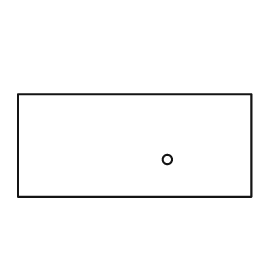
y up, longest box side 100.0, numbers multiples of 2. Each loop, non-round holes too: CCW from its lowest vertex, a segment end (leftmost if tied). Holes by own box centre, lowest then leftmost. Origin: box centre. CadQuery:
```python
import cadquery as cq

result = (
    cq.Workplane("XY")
    .moveTo(-50.0, -22.0)
    .lineTo(50.0, -22.0)
    .lineTo(50.0, 22.0)
    .lineTo(-50.0, 22.0)
    .close()
    .moveTo(14.0, -6.0)
    .circle(2.0)
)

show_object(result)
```